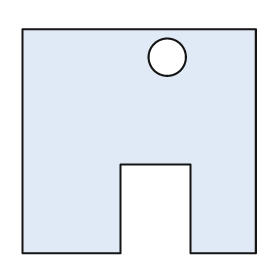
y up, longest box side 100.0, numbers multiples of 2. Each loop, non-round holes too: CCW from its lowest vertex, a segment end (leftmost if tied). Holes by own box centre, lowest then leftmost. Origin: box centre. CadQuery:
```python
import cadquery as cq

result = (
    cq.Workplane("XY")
    .moveTo(-50.0, -48.0)
    .lineTo(-8.0, -48.0)
    .lineTo(-8.0, -10.0)
    .lineTo(22.0, -10.0)
    .lineTo(22.0, -48.0)
    .lineTo(50.0, -48.0)
    .lineTo(50.0, 48.0)
    .lineTo(-50.0, 48.0)
    .close()
    .moveTo(12.0, 36.0)
    .circle(8.0)
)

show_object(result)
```